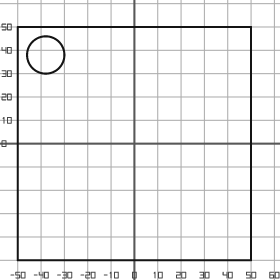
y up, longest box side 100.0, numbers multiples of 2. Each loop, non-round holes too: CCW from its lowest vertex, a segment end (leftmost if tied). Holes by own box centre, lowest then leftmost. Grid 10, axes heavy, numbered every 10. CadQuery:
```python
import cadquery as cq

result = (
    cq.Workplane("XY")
    .moveTo(-50.0, -50.0)
    .lineTo(50.0, -50.0)
    .lineTo(50.0, 50.0)
    .lineTo(-50.0, 50.0)
    .close()
    .moveTo(-38.0, 38.0)
    .circle(8.0)
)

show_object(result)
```